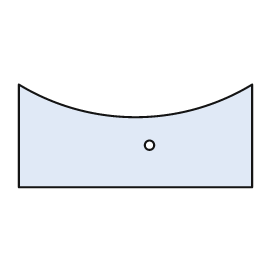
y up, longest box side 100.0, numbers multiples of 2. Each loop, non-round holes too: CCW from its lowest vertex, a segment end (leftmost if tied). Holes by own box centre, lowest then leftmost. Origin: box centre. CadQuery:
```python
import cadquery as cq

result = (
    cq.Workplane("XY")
    .moveTo(-50.0, -22.0)
    .lineTo(50.0, -22.0)
    .lineTo(50.0, 22.0)
    .threePointArc((0.0, 8.0), (-50.0, 22.0))
    .close()
    .moveTo(6.0, -4.0)
    .circle(2.0)
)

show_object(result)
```